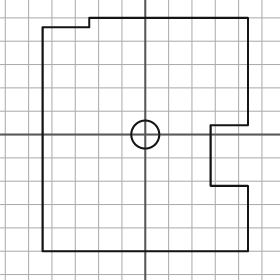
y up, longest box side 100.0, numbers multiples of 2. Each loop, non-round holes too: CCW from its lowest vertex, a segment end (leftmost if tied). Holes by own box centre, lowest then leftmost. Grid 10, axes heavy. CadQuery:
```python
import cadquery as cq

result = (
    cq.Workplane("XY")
    .moveTo(-44.0, -50.0)
    .lineTo(44.0, -50.0)
    .lineTo(44.0, -22.0)
    .lineTo(28.0, -22.0)
    .lineTo(28.0, 4.0)
    .lineTo(44.0, 4.0)
    .lineTo(44.0, 50.0)
    .lineTo(-24.0, 50.0)
    .lineTo(-24.0, 46.0)
    .lineTo(-44.0, 46.0)
    .close()
    .moveTo(0.0, 0.0)
    .circle(6.0)
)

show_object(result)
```